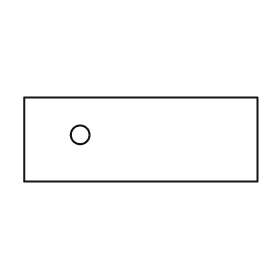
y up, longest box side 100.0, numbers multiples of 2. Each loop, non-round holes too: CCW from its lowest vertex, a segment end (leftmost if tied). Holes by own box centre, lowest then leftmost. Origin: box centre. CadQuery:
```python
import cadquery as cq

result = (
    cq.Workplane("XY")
    .moveTo(-50.0, -18.0)
    .lineTo(50.0, -18.0)
    .lineTo(50.0, 18.0)
    .lineTo(-50.0, 18.0)
    .close()
    .moveTo(-26.0, 2.0)
    .circle(4.0)
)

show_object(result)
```